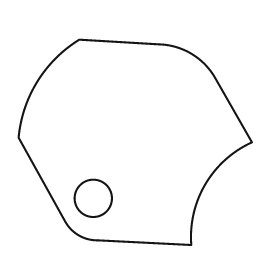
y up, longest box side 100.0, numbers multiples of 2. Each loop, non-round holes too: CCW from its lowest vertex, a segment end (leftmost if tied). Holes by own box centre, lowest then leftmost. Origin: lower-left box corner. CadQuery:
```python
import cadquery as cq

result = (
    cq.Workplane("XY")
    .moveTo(74.0, 0.0)
    .threePointArc((80.0, 26.0), (100.0, 44.0))
    .lineTo(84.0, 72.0)
    .threePointArc((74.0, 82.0), (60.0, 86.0))
    .lineTo(26.0, 88.0)
    .threePointArc((8.0, 70.0), (0.0, 46.0))
    .lineTo(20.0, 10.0)
    .threePointArc((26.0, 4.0), (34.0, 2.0))
    .close()
    .moveTo(32.0, 20.0)
    .circle(8.0)
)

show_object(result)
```